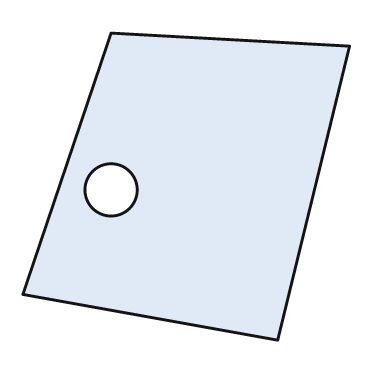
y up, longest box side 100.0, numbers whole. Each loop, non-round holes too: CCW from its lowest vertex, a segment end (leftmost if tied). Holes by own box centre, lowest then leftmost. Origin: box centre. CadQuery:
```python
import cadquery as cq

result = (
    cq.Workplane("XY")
    .moveTo(28.0, -47.0)
    .lineTo(50.0, 43.0)
    .lineTo(-23.0, 47.0)
    .lineTo(-50.0, -33.0)
    .close()
    .moveTo(-23.0, -1.0)
    .circle(8.0)
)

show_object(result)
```